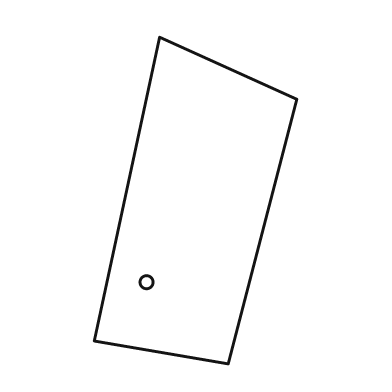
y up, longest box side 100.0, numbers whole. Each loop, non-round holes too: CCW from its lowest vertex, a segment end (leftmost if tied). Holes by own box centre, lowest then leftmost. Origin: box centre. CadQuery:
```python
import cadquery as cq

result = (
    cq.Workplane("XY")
    .moveTo(10.0, -50.0)
    .lineTo(31.0, 31.0)
    .lineTo(-11.0, 50.0)
    .lineTo(-31.0, -43.0)
    .close()
    .moveTo(-15.0, -25.0)
    .circle(2.0)
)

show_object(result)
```